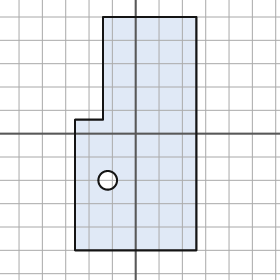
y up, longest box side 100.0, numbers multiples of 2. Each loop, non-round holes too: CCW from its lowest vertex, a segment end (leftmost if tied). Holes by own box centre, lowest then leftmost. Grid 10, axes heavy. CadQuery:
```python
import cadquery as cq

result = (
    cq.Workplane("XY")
    .moveTo(-26.0, -50.0)
    .lineTo(26.0, -50.0)
    .lineTo(26.0, 50.0)
    .lineTo(-14.0, 50.0)
    .lineTo(-14.0, 6.0)
    .lineTo(-26.0, 6.0)
    .close()
    .moveTo(-12.0, -20.0)
    .circle(4.0)
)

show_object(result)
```